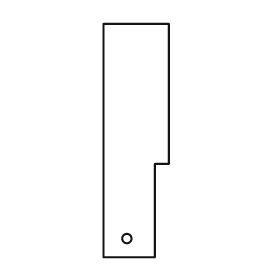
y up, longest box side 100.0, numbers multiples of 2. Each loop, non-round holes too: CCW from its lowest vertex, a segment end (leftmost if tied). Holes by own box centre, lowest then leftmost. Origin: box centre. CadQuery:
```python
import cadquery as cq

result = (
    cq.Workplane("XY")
    .moveTo(-14.0, -50.0)
    .lineTo(8.0, -50.0)
    .lineTo(8.0, -10.0)
    .lineTo(14.0, -10.0)
    .lineTo(14.0, 50.0)
    .lineTo(-14.0, 50.0)
    .close()
    .moveTo(-4.0, -42.0)
    .circle(2.0)
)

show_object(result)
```